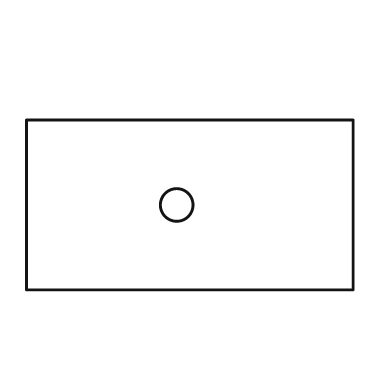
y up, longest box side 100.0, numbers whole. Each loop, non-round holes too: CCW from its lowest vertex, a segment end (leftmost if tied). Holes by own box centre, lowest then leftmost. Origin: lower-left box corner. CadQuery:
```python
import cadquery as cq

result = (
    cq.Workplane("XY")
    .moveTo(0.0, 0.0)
    .lineTo(100.0, 0.0)
    .lineTo(100.0, 52.0)
    .lineTo(0.0, 52.0)
    .close()
    .moveTo(46.0, 26.0)
    .circle(5.0)
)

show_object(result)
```